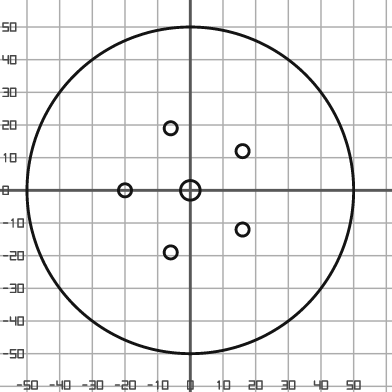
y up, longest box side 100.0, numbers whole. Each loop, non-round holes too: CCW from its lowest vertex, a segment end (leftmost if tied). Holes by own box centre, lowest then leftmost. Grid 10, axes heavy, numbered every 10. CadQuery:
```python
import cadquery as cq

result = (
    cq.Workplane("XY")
    .moveTo(0.0, 0.0)
    .circle(50.0)
    .moveTo(-6.0, -19.0)
    .circle(2.0)
    .moveTo(16.0, -12.0)
    .circle(2.0)
    .moveTo(-20.0, 0.0)
    .circle(2.0)
    .moveTo(0.0, 0.0)
    .circle(3.0)
    .moveTo(16.0, 12.0)
    .circle(2.0)
    .moveTo(-6.0, 19.0)
    .circle(2.0)
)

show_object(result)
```